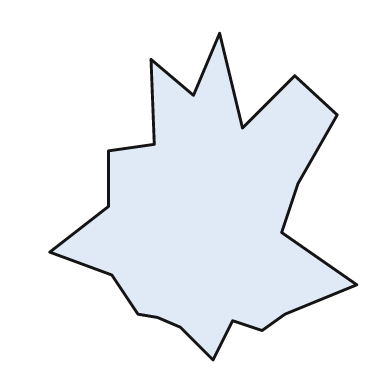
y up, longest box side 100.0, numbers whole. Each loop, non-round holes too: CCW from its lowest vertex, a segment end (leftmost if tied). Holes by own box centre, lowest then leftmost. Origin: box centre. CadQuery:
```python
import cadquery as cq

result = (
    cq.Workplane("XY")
    .moveTo(3.0, -50.0)
    .lineTo(9.0, -38.0)
    .lineTo(18.0, -41.0)
    .lineTo(25.0, -36.0)
    .lineTo(47.0, -27.0)
    .lineTo(24.0, -11.0)
    .lineTo(29.0, 4.0)
    .lineTo(41.0, 25.0)
    .lineTo(28.0, 37.0)
    .lineTo(12.0, 21.0)
    .lineTo(5.0, 50.0)
    .lineTo(-3.0, 31.0)
    .lineTo(-16.0, 42.0)
    .lineTo(-15.0, 16.0)
    .lineTo(-29.0, 14.0)
    .lineTo(-29.0, -3.0)
    .lineTo(-47.0, -17.0)
    .lineTo(-28.0, -24.0)
    .lineTo(-20.0, -36.0)
    .lineTo(-14.0, -37.0)
    .lineTo(-7.0, -40.0)
    .close()
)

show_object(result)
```